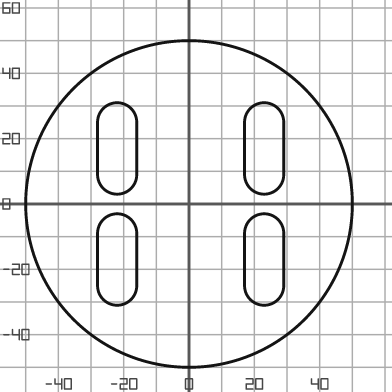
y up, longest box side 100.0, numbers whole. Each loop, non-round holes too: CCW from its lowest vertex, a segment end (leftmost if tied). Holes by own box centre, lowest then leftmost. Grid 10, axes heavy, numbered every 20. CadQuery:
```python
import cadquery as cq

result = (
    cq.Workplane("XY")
    .moveTo(0.0, 0.0)
    .circle(50.0)
    .moveTo(-28.0, -25.0)
    .threePointArc((-22.0, -31.0), (-16.0, -25.0))
    .lineTo(-16.0, -9.0)
    .threePointArc((-22.0, -3.0), (-28.0, -9.0))
    .close()
    .moveTo(17.0, -25.0)
    .threePointArc((23.0, -31.0), (29.0, -25.0))
    .lineTo(29.0, -9.0)
    .threePointArc((23.0, -3.0), (17.0, -9.0))
    .close()
    .moveTo(-28.0, 9.0)
    .threePointArc((-22.0, 3.0), (-16.0, 9.0))
    .lineTo(-16.0, 25.0)
    .threePointArc((-22.0, 31.0), (-28.0, 25.0))
    .close()
    .moveTo(17.0, 9.0)
    .threePointArc((23.0, 3.0), (29.0, 9.0))
    .lineTo(29.0, 25.0)
    .threePointArc((23.0, 31.0), (17.0, 25.0))
    .close()
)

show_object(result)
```